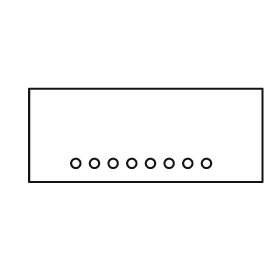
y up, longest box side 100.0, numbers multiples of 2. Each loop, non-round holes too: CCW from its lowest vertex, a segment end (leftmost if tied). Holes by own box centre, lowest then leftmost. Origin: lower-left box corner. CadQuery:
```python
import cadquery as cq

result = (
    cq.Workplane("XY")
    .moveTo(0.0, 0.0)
    .lineTo(100.0, 0.0)
    .lineTo(100.0, 40.0)
    .lineTo(0.0, 40.0)
    .close()
    .moveTo(20.0, 8.0)
    .circle(2.0)
    .moveTo(28.0, 8.0)
    .circle(2.0)
    .moveTo(36.0, 8.0)
    .circle(2.0)
    .moveTo(44.0, 8.0)
    .circle(2.0)
    .moveTo(52.0, 8.0)
    .circle(2.0)
    .moveTo(60.0, 8.0)
    .circle(2.0)
    .moveTo(68.0, 8.0)
    .circle(2.0)
    .moveTo(76.0, 8.0)
    .circle(2.0)
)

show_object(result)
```